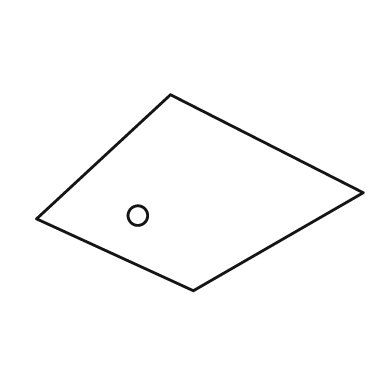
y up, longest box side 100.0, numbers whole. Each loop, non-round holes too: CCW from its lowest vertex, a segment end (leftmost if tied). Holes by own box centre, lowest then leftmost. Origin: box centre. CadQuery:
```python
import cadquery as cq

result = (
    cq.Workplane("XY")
    .moveTo(-2.0, -30.0)
    .lineTo(50.0, 0.0)
    .lineTo(-9.0, 30.0)
    .lineTo(-50.0, -8.0)
    .close()
    .moveTo(-19.0, -7.0)
    .circle(3.0)
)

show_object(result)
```